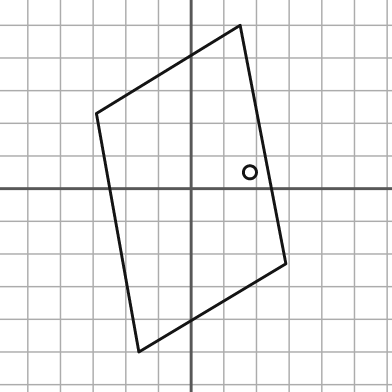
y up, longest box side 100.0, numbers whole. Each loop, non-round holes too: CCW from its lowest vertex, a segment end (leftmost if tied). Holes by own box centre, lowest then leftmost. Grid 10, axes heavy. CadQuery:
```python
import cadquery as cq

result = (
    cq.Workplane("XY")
    .moveTo(-16.0, -50.0)
    .lineTo(29.0, -23.0)
    .lineTo(15.0, 50.0)
    .lineTo(-29.0, 23.0)
    .close()
    .moveTo(18.0, 5.0)
    .circle(2.0)
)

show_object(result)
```